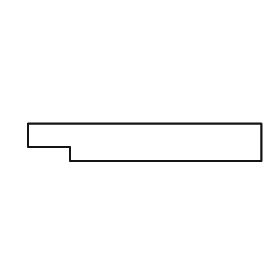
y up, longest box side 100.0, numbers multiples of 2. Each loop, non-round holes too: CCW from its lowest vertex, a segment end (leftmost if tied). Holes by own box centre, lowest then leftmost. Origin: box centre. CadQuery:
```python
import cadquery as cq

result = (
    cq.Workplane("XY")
    .moveTo(-32.0, -8.0)
    .lineTo(50.0, -8.0)
    .lineTo(50.0, 8.0)
    .lineTo(-50.0, 8.0)
    .lineTo(-50.0, -2.0)
    .lineTo(-32.0, -2.0)
    .close()
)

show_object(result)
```